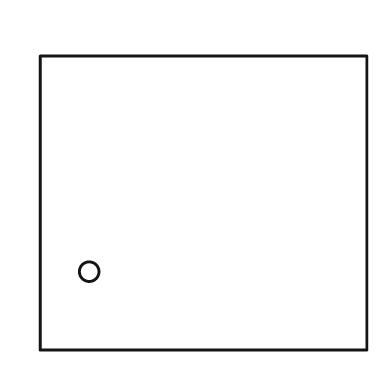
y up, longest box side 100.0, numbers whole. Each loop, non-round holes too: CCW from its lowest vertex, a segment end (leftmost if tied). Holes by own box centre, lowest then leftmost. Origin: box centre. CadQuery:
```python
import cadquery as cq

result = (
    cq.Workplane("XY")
    .moveTo(-50.0, -45.0)
    .lineTo(50.0, -45.0)
    .lineTo(50.0, 45.0)
    .lineTo(-50.0, 45.0)
    .close()
    .moveTo(-35.0, -21.0)
    .circle(3.0)
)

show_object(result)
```